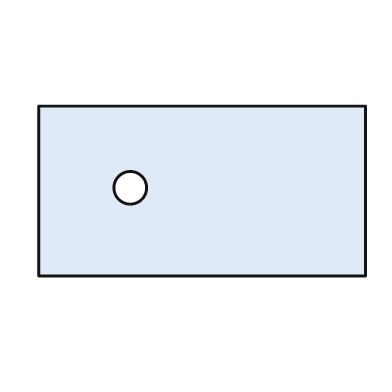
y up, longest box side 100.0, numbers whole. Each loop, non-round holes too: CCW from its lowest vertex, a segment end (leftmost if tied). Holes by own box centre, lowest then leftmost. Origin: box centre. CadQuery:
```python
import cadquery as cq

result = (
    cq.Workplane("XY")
    .moveTo(-50.0, -26.0)
    .lineTo(50.0, -26.0)
    .lineTo(50.0, 26.0)
    .lineTo(-50.0, 26.0)
    .close()
    .moveTo(-22.0, 1.0)
    .circle(5.0)
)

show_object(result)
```